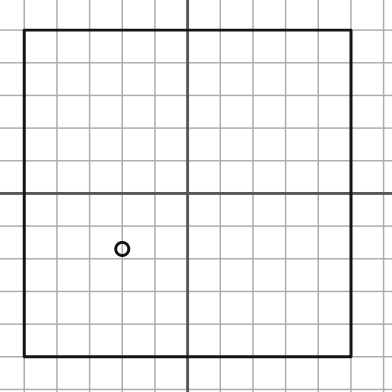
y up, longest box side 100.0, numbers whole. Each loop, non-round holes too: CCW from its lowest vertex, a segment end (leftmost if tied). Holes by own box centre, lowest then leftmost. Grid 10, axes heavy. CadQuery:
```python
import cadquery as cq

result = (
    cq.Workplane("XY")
    .moveTo(-50.0, -50.0)
    .lineTo(50.0, -50.0)
    .lineTo(50.0, 50.0)
    .lineTo(-50.0, 50.0)
    .close()
    .moveTo(-20.0, -17.0)
    .circle(2.0)
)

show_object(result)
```